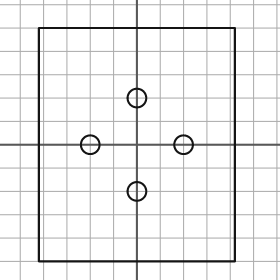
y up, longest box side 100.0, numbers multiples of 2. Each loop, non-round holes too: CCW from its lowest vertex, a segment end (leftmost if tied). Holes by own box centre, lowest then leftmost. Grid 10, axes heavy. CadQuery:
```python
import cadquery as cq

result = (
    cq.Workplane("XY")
    .moveTo(-42.0, -50.0)
    .lineTo(42.0, -50.0)
    .lineTo(42.0, 50.0)
    .lineTo(-42.0, 50.0)
    .close()
    .moveTo(0.0, -20.0)
    .circle(4.0)
    .moveTo(-20.0, 0.0)
    .circle(4.0)
    .moveTo(20.0, 0.0)
    .circle(4.0)
    .moveTo(0.0, 20.0)
    .circle(4.0)
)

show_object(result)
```